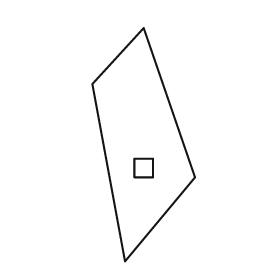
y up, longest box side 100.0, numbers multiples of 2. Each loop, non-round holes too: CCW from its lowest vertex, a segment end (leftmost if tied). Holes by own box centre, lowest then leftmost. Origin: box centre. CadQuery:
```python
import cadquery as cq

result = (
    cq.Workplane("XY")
    .moveTo(-8.0, -50.0)
    .lineTo(22.0, -14.0)
    .lineTo(0.0, 50.0)
    .lineTo(-22.0, 26.0)
    .close()
    .moveTo(-4.0, -14.0)
    .lineTo(4.0, -14.0)
    .lineTo(4.0, -6.0)
    .lineTo(-4.0, -6.0)
    .close()
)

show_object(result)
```